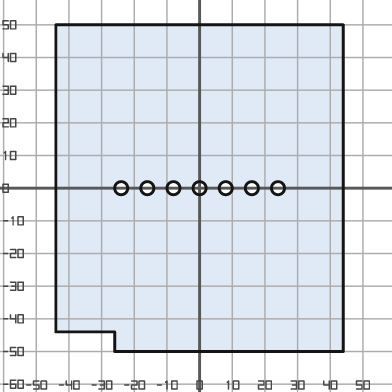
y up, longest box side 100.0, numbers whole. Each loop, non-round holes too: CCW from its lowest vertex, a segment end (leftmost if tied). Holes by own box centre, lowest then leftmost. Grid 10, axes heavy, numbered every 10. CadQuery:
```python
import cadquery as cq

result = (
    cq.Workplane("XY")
    .moveTo(-26.0, -50.0)
    .lineTo(44.0, -50.0)
    .lineTo(44.0, 50.0)
    .lineTo(-44.0, 50.0)
    .lineTo(-44.0, -44.0)
    .lineTo(-26.0, -44.0)
    .close()
    .moveTo(-24.0, 0.0)
    .circle(2.0)
    .moveTo(-16.0, 0.0)
    .circle(2.0)
    .moveTo(-8.0, 0.0)
    .circle(2.0)
    .moveTo(0.0, 0.0)
    .circle(2.0)
    .moveTo(8.0, 0.0)
    .circle(2.0)
    .moveTo(16.0, 0.0)
    .circle(2.0)
    .moveTo(24.0, 0.0)
    .circle(2.0)
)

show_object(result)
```